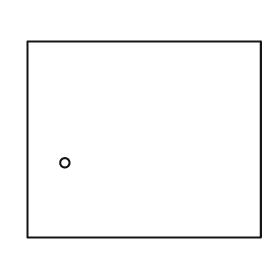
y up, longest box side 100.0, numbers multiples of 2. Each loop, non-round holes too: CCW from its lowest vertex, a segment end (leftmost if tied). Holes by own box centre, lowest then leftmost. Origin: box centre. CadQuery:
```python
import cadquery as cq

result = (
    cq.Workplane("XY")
    .moveTo(-50.0, -42.0)
    .lineTo(50.0, -42.0)
    .lineTo(50.0, 42.0)
    .lineTo(-50.0, 42.0)
    .close()
    .moveTo(-34.0, -10.0)
    .circle(2.0)
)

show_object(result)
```